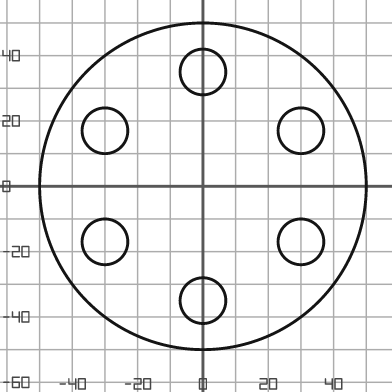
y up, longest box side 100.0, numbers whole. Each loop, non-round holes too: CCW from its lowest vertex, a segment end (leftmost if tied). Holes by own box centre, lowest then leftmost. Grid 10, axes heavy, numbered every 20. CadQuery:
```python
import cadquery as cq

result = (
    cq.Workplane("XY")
    .moveTo(0.0, 0.0)
    .circle(50.0)
    .moveTo(0.0, -35.0)
    .circle(7.0)
    .moveTo(-30.0, -17.0)
    .circle(7.0)
    .moveTo(30.0, -17.0)
    .circle(7.0)
    .moveTo(-30.0, 17.0)
    .circle(7.0)
    .moveTo(30.0, 17.0)
    .circle(7.0)
    .moveTo(0.0, 35.0)
    .circle(7.0)
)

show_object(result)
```